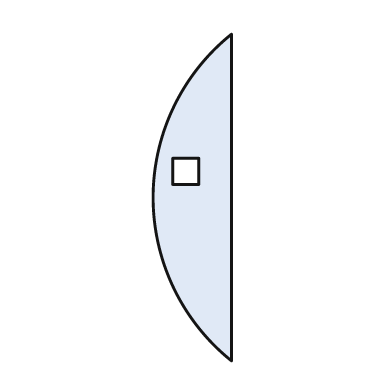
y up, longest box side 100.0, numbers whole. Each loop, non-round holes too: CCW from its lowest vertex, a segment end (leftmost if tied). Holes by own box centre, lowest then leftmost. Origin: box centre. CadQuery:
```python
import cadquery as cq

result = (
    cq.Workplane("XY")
    .moveTo(12.0, -50.0)
    .lineTo(12.0, 50.0)
    .threePointArc((-12.0, 0.0), (12.0, -50.0))
    .close()
    .moveTo(-6.0, 4.0)
    .lineTo(2.0, 4.0)
    .lineTo(2.0, 12.0)
    .lineTo(-6.0, 12.0)
    .close()
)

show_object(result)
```